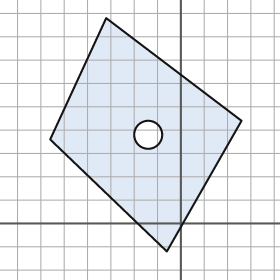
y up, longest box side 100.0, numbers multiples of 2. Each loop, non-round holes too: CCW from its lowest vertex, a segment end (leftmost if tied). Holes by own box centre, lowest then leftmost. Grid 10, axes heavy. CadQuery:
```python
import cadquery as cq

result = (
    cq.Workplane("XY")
    .moveTo(-6.0, -12.0)
    .lineTo(26.0, 44.0)
    .lineTo(-32.0, 88.0)
    .lineTo(-56.0, 36.0)
    .close()
    .moveTo(-14.0, 38.0)
    .circle(6.0)
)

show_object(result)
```